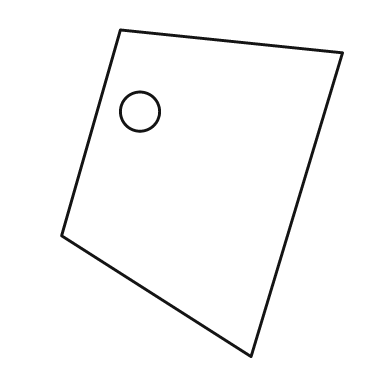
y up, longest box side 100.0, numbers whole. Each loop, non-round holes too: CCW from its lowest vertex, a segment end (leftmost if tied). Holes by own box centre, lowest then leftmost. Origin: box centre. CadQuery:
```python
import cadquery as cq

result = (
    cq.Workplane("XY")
    .moveTo(15.0, -50.0)
    .lineTo(43.0, 43.0)
    .lineTo(-25.0, 50.0)
    .lineTo(-43.0, -13.0)
    .close()
    .moveTo(-19.0, 25.0)
    .circle(6.0)
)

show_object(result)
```